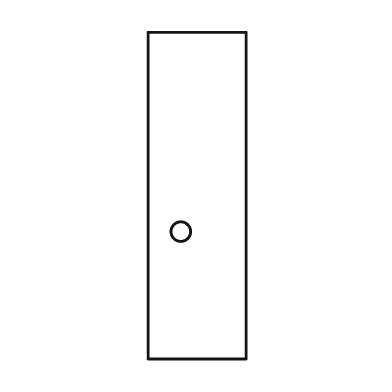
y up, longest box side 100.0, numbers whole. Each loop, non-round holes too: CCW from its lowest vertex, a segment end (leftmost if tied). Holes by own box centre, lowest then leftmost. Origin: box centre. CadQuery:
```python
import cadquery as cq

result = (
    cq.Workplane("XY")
    .moveTo(-15.0, -50.0)
    .lineTo(15.0, -50.0)
    .lineTo(15.0, 50.0)
    .lineTo(-15.0, 50.0)
    .close()
    .moveTo(-5.0, -11.0)
    .circle(3.0)
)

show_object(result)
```